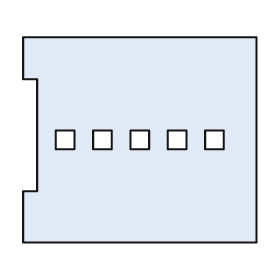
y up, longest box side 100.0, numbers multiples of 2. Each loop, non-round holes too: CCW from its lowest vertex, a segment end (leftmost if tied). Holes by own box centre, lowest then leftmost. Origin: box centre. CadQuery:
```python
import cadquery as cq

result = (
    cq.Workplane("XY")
    .moveTo(-50.0, -44.0)
    .lineTo(50.0, -44.0)
    .lineTo(50.0, 44.0)
    .lineTo(-50.0, 44.0)
    .lineTo(-50.0, 26.0)
    .lineTo(-44.0, 26.0)
    .lineTo(-44.0, -22.0)
    .lineTo(-50.0, -22.0)
    .close()
    .moveTo(-36.0, -4.0)
    .lineTo(-28.0, -4.0)
    .lineTo(-28.0, 4.0)
    .lineTo(-36.0, 4.0)
    .close()
    .moveTo(-20.0, -4.0)
    .lineTo(-12.0, -4.0)
    .lineTo(-12.0, 4.0)
    .lineTo(-20.0, 4.0)
    .close()
    .moveTo(-4.0, -4.0)
    .lineTo(4.0, -4.0)
    .lineTo(4.0, 4.0)
    .lineTo(-4.0, 4.0)
    .close()
    .moveTo(12.0, -4.0)
    .lineTo(20.0, -4.0)
    .lineTo(20.0, 4.0)
    .lineTo(12.0, 4.0)
    .close()
    .moveTo(28.0, -4.0)
    .lineTo(36.0, -4.0)
    .lineTo(36.0, 4.0)
    .lineTo(28.0, 4.0)
    .close()
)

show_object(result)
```